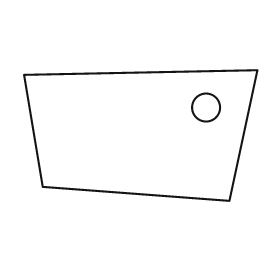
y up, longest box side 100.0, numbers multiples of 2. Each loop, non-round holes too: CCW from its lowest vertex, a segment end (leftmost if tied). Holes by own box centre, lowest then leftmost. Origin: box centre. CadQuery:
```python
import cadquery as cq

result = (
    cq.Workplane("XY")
    .moveTo(38.0, -28.0)
    .lineTo(50.0, 28.0)
    .lineTo(-50.0, 26.0)
    .lineTo(-42.0, -22.0)
    .close()
    .moveTo(28.0, 12.0)
    .circle(6.0)
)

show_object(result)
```